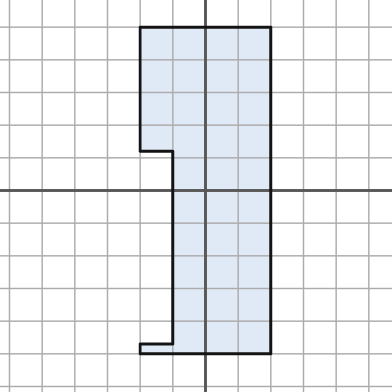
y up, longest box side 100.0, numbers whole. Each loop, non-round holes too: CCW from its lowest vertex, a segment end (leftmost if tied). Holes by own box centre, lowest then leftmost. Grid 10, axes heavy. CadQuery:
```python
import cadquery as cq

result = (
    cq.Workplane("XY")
    .moveTo(-20.0, -50.0)
    .lineTo(20.0, -50.0)
    .lineTo(20.0, 50.0)
    .lineTo(-20.0, 50.0)
    .lineTo(-20.0, 12.0)
    .lineTo(-10.0, 12.0)
    .lineTo(-10.0, -47.0)
    .lineTo(-20.0, -47.0)
    .close()
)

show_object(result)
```